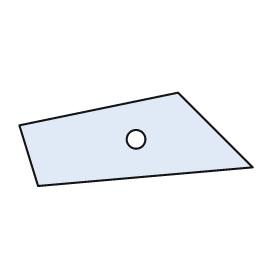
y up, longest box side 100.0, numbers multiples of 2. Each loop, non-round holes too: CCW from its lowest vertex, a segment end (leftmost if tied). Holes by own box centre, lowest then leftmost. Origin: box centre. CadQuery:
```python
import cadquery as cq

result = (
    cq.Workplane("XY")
    .moveTo(-42.0, -20.0)
    .lineTo(50.0, -12.0)
    .lineTo(18.0, 20.0)
    .lineTo(-50.0, 6.0)
    .close()
    .moveTo(0.0, 0.0)
    .circle(4.0)
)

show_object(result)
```